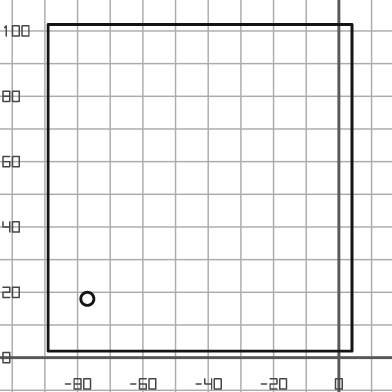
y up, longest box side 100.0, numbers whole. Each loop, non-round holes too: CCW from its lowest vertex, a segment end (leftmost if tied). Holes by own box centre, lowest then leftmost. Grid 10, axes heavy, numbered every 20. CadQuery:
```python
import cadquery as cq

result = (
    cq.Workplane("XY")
    .moveTo(-89.0, 2.0)
    .lineTo(4.0, 2.0)
    .lineTo(4.0, 102.0)
    .lineTo(-89.0, 102.0)
    .close()
    .moveTo(-77.0, 18.0)
    .circle(2.0)
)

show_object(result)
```